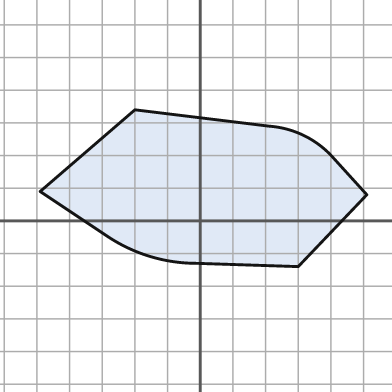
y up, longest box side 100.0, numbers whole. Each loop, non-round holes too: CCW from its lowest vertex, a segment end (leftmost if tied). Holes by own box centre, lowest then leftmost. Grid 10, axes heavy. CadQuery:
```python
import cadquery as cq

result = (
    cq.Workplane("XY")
    .moveTo(30.0, -14.0)
    .lineTo(51.0, 8.0)
    .lineTo(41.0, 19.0)
    .threePointArc((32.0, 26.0), (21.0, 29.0))
    .lineTo(-20.0, 34.0)
    .lineTo(-49.0, 9.0)
    .lineTo(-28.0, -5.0)
    .threePointArc((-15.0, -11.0), (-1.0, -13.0))
    .close()
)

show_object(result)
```